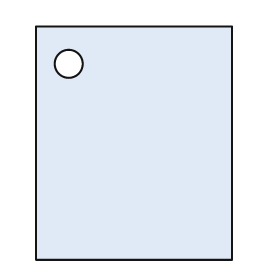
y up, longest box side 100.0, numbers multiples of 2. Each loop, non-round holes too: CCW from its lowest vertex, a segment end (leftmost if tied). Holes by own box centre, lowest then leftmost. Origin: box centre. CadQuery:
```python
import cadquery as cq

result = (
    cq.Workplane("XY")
    .moveTo(-42.0, -50.0)
    .lineTo(42.0, -50.0)
    .lineTo(42.0, 50.0)
    .lineTo(-42.0, 50.0)
    .close()
    .moveTo(-28.0, 34.0)
    .circle(6.0)
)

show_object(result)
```